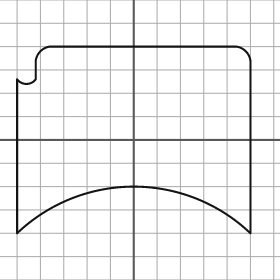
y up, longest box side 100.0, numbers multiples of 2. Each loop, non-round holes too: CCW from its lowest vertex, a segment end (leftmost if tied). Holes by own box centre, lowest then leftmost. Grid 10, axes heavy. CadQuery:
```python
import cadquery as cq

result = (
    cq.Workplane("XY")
    .moveTo(-50.0, -40.0)
    .threePointArc((0.0, -20.0), (50.0, -40.0))
    .lineTo(50.0, 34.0)
    .threePointArc((48.0, 38.0), (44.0, 40.0))
    .lineTo(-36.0, 40.0)
    .threePointArc((-40.0, 38.0), (-42.0, 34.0))
    .lineTo(-42.0, 26.0)
    .threePointArc((-46.0, 24.0), (-50.0, 26.0))
    .close()
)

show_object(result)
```